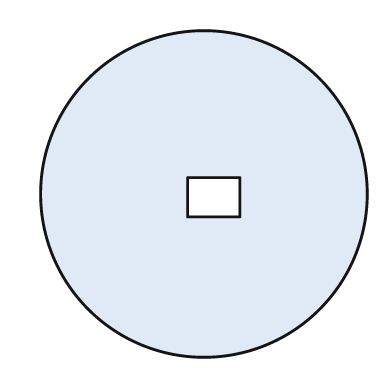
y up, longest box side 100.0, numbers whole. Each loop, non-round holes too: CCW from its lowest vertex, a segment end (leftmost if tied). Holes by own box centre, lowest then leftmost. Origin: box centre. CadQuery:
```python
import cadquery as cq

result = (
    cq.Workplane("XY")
    .moveTo(0.0, 0.0)
    .circle(50.0)
    .moveTo(-5.0, -7.0)
    .lineTo(11.0, -7.0)
    .lineTo(11.0, 5.0)
    .lineTo(-5.0, 5.0)
    .close()
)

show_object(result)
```